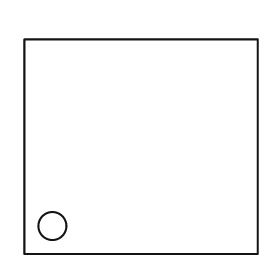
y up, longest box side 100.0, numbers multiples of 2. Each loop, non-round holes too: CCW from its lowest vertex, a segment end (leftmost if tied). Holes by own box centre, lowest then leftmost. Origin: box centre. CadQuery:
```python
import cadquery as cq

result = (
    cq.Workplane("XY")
    .moveTo(-50.0, -46.0)
    .lineTo(50.0, -46.0)
    .lineTo(50.0, 46.0)
    .lineTo(-50.0, 46.0)
    .close()
    .moveTo(-38.0, -34.0)
    .circle(6.0)
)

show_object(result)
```